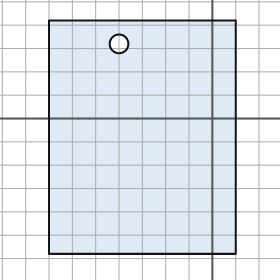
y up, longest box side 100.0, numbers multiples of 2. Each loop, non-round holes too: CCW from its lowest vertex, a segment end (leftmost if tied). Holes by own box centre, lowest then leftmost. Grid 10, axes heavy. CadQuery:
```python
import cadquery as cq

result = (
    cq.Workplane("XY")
    .moveTo(-70.0, -58.0)
    .lineTo(10.0, -58.0)
    .lineTo(10.0, 42.0)
    .lineTo(-70.0, 42.0)
    .close()
    .moveTo(-40.0, 32.0)
    .circle(4.0)
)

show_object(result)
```